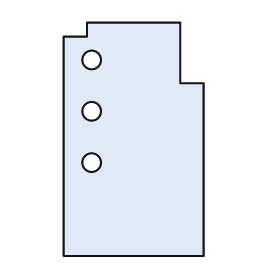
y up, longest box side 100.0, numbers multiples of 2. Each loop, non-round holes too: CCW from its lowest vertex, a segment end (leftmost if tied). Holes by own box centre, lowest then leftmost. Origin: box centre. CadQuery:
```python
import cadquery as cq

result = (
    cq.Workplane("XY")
    .moveTo(-30.0, -50.0)
    .lineTo(30.0, -50.0)
    .lineTo(30.0, 24.0)
    .lineTo(20.0, 24.0)
    .lineTo(20.0, 50.0)
    .lineTo(-20.0, 50.0)
    .lineTo(-20.0, 44.0)
    .lineTo(-30.0, 44.0)
    .close()
    .moveTo(-18.0, -10.0)
    .circle(4.0)
    .moveTo(-18.0, 12.0)
    .circle(4.0)
    .moveTo(-18.0, 34.0)
    .circle(4.0)
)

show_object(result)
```